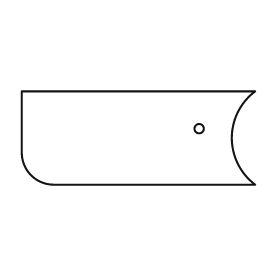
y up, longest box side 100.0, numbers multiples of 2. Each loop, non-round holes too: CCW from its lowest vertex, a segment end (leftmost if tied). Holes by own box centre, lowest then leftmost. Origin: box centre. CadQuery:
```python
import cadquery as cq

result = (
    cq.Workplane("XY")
    .moveTo(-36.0, -20.0)
    .lineTo(50.0, -20.0)
    .threePointArc((40.0, 0.0), (50.0, 20.0))
    .lineTo(-50.0, 20.0)
    .lineTo(-50.0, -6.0)
    .threePointArc((-46.0, -16.0), (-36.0, -20.0))
    .close()
    .moveTo(26.0, 4.0)
    .circle(2.0)
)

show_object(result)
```